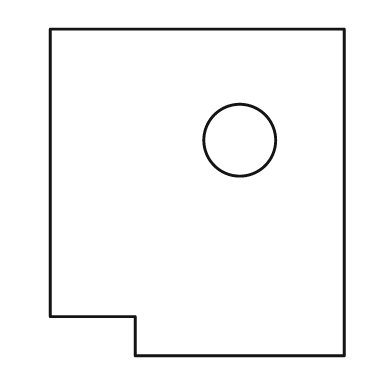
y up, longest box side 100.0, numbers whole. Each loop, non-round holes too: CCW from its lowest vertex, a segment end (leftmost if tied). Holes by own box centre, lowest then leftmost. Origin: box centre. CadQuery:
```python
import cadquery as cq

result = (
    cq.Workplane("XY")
    .moveTo(-19.0, -50.0)
    .lineTo(45.0, -50.0)
    .lineTo(45.0, 50.0)
    .lineTo(-45.0, 50.0)
    .lineTo(-45.0, -38.0)
    .lineTo(-19.0, -38.0)
    .close()
    .moveTo(13.0, 16.0)
    .circle(11.0)
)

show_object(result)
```